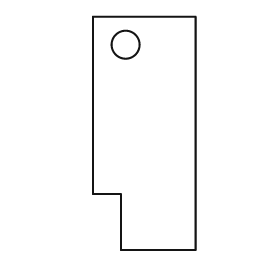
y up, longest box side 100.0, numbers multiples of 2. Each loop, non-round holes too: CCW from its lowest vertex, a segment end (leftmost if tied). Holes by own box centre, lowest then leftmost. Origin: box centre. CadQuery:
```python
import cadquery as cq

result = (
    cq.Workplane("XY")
    .moveTo(-10.0, -50.0)
    .lineTo(22.0, -50.0)
    .lineTo(22.0, 50.0)
    .lineTo(-22.0, 50.0)
    .lineTo(-22.0, -26.0)
    .lineTo(-10.0, -26.0)
    .close()
    .moveTo(-8.0, 38.0)
    .circle(6.0)
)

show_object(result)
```